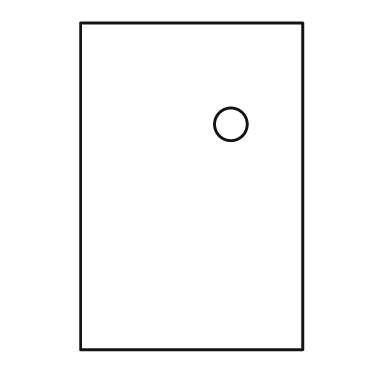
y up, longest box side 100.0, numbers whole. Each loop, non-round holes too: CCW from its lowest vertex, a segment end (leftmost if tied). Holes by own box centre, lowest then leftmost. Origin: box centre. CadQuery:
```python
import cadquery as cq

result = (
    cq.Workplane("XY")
    .moveTo(-34.0, -50.0)
    .lineTo(34.0, -50.0)
    .lineTo(34.0, 50.0)
    .lineTo(-34.0, 50.0)
    .close()
    .moveTo(12.0, 19.0)
    .circle(5.0)
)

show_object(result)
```